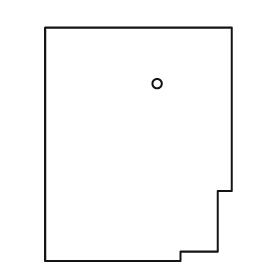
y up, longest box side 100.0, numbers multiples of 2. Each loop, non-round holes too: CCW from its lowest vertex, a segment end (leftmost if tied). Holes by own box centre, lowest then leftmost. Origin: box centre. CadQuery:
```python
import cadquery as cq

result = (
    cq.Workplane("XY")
    .moveTo(-40.0, -50.0)
    .lineTo(18.0, -50.0)
    .lineTo(18.0, -46.0)
    .lineTo(34.0, -46.0)
    .lineTo(34.0, -20.0)
    .lineTo(40.0, -20.0)
    .lineTo(40.0, 50.0)
    .lineTo(-40.0, 50.0)
    .close()
    .moveTo(8.0, 26.0)
    .circle(2.0)
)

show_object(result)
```